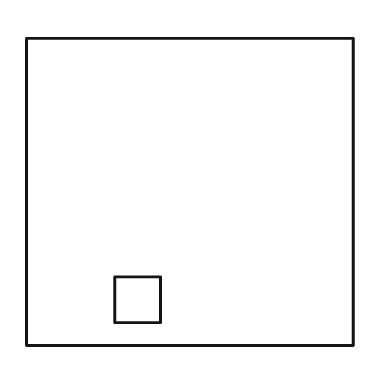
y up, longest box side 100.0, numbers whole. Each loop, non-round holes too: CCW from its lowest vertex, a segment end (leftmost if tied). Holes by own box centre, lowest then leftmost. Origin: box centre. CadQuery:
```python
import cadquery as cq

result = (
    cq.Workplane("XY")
    .moveTo(-50.0, -47.0)
    .lineTo(50.0, -47.0)
    .lineTo(50.0, 47.0)
    .lineTo(-50.0, 47.0)
    .close()
    .moveTo(-23.0, -40.0)
    .lineTo(-9.0, -40.0)
    .lineTo(-9.0, -26.0)
    .lineTo(-23.0, -26.0)
    .close()
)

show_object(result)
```